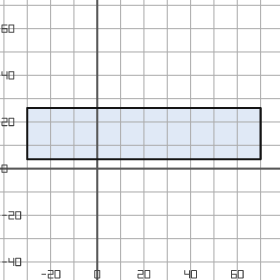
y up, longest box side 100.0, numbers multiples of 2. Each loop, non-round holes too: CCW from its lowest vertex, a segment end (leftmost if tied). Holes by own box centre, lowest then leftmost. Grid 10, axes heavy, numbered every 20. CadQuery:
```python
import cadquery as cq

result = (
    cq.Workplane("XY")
    .moveTo(-30.0, 4.0)
    .lineTo(70.0, 4.0)
    .lineTo(70.0, 26.0)
    .lineTo(-30.0, 26.0)
    .close()
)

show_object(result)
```